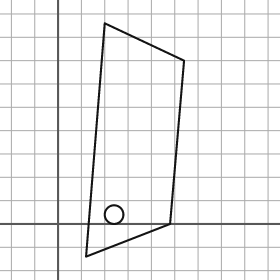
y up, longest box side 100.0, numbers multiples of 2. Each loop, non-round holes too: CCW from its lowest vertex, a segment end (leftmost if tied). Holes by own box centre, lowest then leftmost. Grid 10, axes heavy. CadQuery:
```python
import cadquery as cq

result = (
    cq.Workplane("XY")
    .moveTo(12.0, -14.0)
    .lineTo(48.0, 0.0)
    .lineTo(54.0, 70.0)
    .lineTo(20.0, 86.0)
    .close()
    .moveTo(24.0, 4.0)
    .circle(4.0)
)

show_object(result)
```